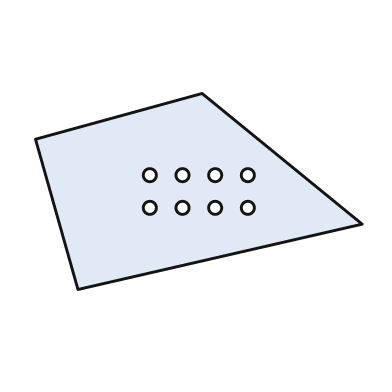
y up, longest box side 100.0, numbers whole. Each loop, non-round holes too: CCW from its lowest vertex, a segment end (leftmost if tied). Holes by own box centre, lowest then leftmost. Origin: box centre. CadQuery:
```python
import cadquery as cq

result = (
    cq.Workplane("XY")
    .moveTo(-37.0, -30.0)
    .lineTo(50.0, -10.0)
    .lineTo(1.0, 30.0)
    .lineTo(-50.0, 16.0)
    .close()
    .moveTo(-15.0, -5.0)
    .circle(2.0)
    .moveTo(-5.0, -5.0)
    .circle(2.0)
    .moveTo(5.0, -5.0)
    .circle(2.0)
    .moveTo(15.0, -5.0)
    .circle(2.0)
    .moveTo(-15.0, 5.0)
    .circle(2.0)
    .moveTo(-5.0, 5.0)
    .circle(2.0)
    .moveTo(5.0, 5.0)
    .circle(2.0)
    .moveTo(15.0, 5.0)
    .circle(2.0)
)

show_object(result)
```